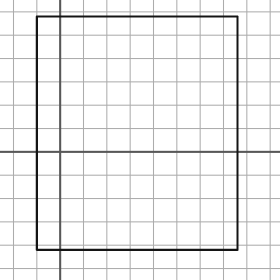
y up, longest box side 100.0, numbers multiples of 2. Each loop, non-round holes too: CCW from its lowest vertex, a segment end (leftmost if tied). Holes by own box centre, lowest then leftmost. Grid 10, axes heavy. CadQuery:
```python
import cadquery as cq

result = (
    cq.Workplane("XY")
    .moveTo(-10.0, -42.0)
    .lineTo(76.0, -42.0)
    .lineTo(76.0, 58.0)
    .lineTo(-10.0, 58.0)
    .close()
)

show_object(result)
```